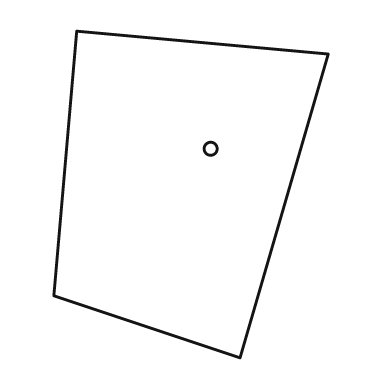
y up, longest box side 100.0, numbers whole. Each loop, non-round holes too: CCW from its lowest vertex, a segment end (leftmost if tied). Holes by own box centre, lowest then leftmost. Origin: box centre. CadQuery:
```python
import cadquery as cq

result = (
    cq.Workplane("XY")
    .moveTo(15.0, -50.0)
    .lineTo(42.0, 43.0)
    .lineTo(-35.0, 50.0)
    .lineTo(-42.0, -31.0)
    .close()
    .moveTo(6.0, 14.0)
    .circle(2.0)
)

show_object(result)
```